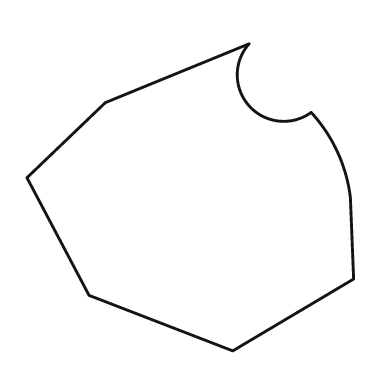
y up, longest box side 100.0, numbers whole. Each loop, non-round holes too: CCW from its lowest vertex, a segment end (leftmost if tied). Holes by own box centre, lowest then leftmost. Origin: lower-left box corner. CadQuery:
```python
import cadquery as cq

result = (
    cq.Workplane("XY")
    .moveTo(63.0, 0.0)
    .lineTo(100.0, 22.0)
    .lineTo(99.0, 47.0)
    .threePointArc((95.0, 61.0), (87.0, 73.0))
    .threePointArc((68.0, 75.0), (68.0, 94.0))
    .lineTo(24.0, 76.0)
    .lineTo(0.0, 53.0)
    .lineTo(19.0, 17.0)
    .close()
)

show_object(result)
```